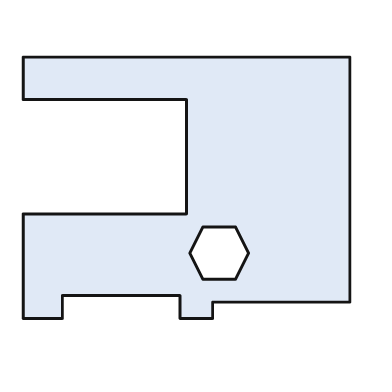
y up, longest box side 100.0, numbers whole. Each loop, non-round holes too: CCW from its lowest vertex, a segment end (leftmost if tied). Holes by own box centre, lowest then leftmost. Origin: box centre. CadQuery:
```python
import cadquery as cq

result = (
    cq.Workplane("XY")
    .moveTo(-50.0, -40.0)
    .lineTo(-38.0, -40.0)
    .lineTo(-38.0, -33.0)
    .lineTo(-2.0, -33.0)
    .lineTo(-2.0, -40.0)
    .lineTo(8.0, -40.0)
    .lineTo(8.0, -35.0)
    .lineTo(50.0, -35.0)
    .lineTo(50.0, 40.0)
    .lineTo(-50.0, 40.0)
    .lineTo(-50.0, 27.0)
    .lineTo(0.0, 27.0)
    .lineTo(0.0, -8.0)
    .lineTo(-50.0, -8.0)
    .close()
    .moveTo(5.0, -28.0)
    .lineTo(15.0, -28.0)
    .lineTo(19.0, -20.0)
    .lineTo(15.0, -12.0)
    .lineTo(5.0, -12.0)
    .lineTo(1.0, -20.0)
    .close()
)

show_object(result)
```